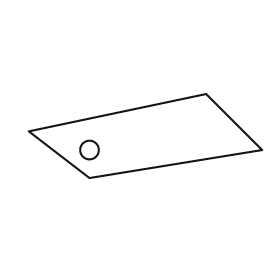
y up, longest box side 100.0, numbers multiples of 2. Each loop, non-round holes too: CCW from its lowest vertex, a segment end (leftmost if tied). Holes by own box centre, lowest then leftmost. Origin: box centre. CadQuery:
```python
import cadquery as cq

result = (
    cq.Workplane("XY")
    .moveTo(-24.0, -18.0)
    .lineTo(50.0, -6.0)
    .lineTo(26.0, 18.0)
    .lineTo(-50.0, 2.0)
    .close()
    .moveTo(-24.0, -6.0)
    .circle(4.0)
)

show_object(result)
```